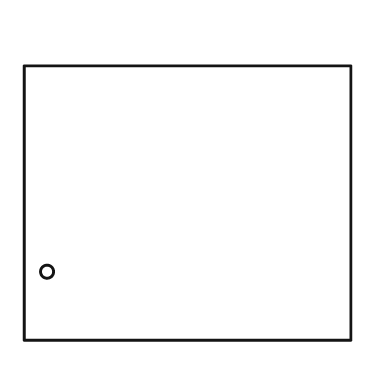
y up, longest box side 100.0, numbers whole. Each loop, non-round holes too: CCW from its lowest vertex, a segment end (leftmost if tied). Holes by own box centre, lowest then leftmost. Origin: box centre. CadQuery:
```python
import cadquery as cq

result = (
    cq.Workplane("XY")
    .moveTo(-50.0, -42.0)
    .lineTo(50.0, -42.0)
    .lineTo(50.0, 42.0)
    .lineTo(-50.0, 42.0)
    .close()
    .moveTo(-43.0, -21.0)
    .circle(2.0)
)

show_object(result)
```